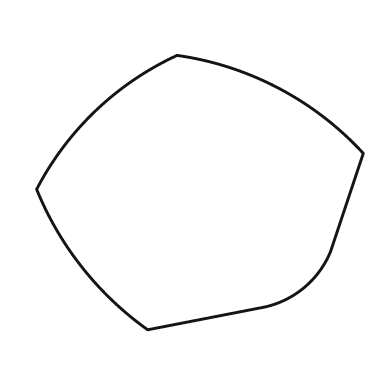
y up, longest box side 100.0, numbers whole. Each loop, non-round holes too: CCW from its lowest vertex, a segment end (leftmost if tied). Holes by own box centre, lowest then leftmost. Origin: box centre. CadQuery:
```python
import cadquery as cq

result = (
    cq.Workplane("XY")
    .moveTo(-16.0, -42.0)
    .lineTo(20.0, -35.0)
    .threePointArc((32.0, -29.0), (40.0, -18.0))
    .lineTo(50.0, 12.0)
    .threePointArc((24.0, 32.0), (-7.0, 42.0))
    .threePointArc((-32.0, 25.0), (-50.0, 1.0))
    .threePointArc((-36.0, -23.0), (-16.0, -42.0))
    .close()
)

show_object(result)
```